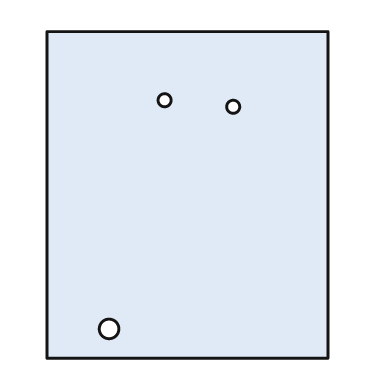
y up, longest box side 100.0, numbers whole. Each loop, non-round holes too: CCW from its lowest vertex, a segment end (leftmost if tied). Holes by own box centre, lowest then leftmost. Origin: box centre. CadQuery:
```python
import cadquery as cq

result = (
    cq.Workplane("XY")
    .moveTo(-43.0, -50.0)
    .lineTo(43.0, -50.0)
    .lineTo(43.0, 50.0)
    .lineTo(-43.0, 50.0)
    .close()
    .moveTo(-24.0, -41.0)
    .circle(3.0)
    .moveTo(14.0, 27.0)
    .circle(2.0)
    .moveTo(-7.0, 29.0)
    .circle(2.0)
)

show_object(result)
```